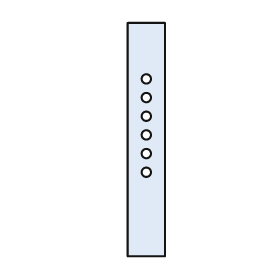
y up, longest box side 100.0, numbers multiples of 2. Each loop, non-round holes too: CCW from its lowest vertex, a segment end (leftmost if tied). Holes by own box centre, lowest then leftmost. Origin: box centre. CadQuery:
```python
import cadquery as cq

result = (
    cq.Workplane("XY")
    .moveTo(-8.0, -50.0)
    .lineTo(8.0, -50.0)
    .lineTo(8.0, 50.0)
    .lineTo(-8.0, 50.0)
    .close()
    .moveTo(0.0, -14.0)
    .circle(2.0)
    .moveTo(0.0, -6.0)
    .circle(2.0)
    .moveTo(0.0, 2.0)
    .circle(2.0)
    .moveTo(0.0, 10.0)
    .circle(2.0)
    .moveTo(0.0, 18.0)
    .circle(2.0)
    .moveTo(0.0, 26.0)
    .circle(2.0)
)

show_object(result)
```